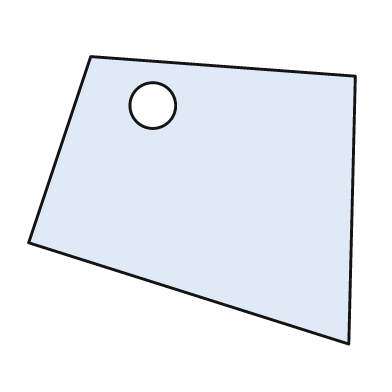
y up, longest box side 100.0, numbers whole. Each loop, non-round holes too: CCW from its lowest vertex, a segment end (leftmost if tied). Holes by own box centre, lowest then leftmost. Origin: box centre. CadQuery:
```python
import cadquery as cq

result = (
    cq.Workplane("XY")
    .moveTo(48.0, -44.0)
    .lineTo(50.0, 38.0)
    .lineTo(-31.0, 44.0)
    .lineTo(-50.0, -13.0)
    .close()
    .moveTo(-12.0, 29.0)
    .circle(7.0)
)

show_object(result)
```